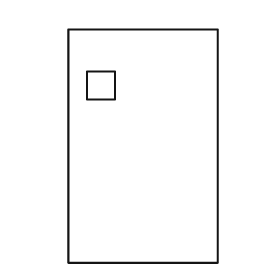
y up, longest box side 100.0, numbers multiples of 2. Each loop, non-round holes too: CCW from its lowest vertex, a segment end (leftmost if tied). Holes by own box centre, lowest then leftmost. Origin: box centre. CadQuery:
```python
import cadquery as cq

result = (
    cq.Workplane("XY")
    .moveTo(-32.0, -50.0)
    .lineTo(32.0, -50.0)
    .lineTo(32.0, 50.0)
    .lineTo(-32.0, 50.0)
    .close()
    .moveTo(-24.0, 20.0)
    .lineTo(-12.0, 20.0)
    .lineTo(-12.0, 32.0)
    .lineTo(-24.0, 32.0)
    .close()
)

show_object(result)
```